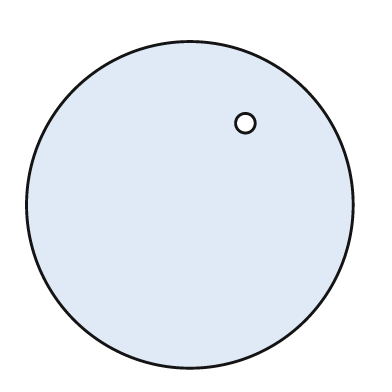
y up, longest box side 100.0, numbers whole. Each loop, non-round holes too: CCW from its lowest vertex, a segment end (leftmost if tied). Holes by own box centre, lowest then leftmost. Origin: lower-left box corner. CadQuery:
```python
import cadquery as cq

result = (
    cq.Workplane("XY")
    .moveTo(50.0, 50.0)
    .circle(50.0)
    .moveTo(67.0, 75.0)
    .circle(3.0)
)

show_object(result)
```